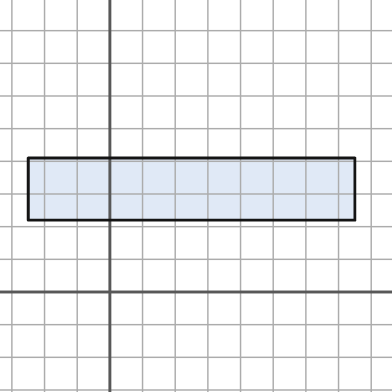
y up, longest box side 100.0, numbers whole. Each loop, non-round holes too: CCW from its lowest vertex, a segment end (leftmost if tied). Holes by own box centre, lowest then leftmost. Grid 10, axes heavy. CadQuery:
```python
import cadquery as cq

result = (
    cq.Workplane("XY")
    .moveTo(-25.0, 22.0)
    .lineTo(75.0, 22.0)
    .lineTo(75.0, 41.0)
    .lineTo(-25.0, 41.0)
    .close()
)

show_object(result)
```